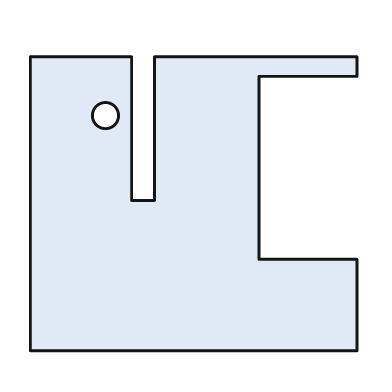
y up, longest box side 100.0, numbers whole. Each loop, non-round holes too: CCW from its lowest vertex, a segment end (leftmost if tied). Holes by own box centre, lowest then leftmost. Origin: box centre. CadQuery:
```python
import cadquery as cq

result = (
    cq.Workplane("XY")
    .moveTo(-50.0, -45.0)
    .lineTo(50.0, -45.0)
    .lineTo(50.0, -17.0)
    .lineTo(20.0, -17.0)
    .lineTo(20.0, 39.0)
    .lineTo(50.0, 39.0)
    .lineTo(50.0, 45.0)
    .lineTo(-12.0, 45.0)
    .lineTo(-12.0, 1.0)
    .lineTo(-19.0, 1.0)
    .lineTo(-19.0, 45.0)
    .lineTo(-50.0, 45.0)
    .close()
    .moveTo(-27.0, 27.0)
    .circle(4.0)
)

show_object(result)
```